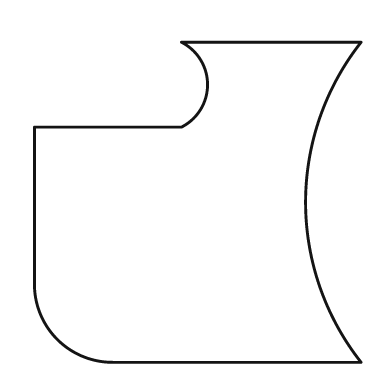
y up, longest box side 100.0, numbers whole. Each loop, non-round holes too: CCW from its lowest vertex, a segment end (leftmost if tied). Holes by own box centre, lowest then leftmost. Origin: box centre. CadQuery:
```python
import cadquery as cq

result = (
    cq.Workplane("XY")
    .moveTo(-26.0, -49.0)
    .lineTo(50.0, -49.0)
    .threePointArc((33.0, 0.0), (50.0, 49.0))
    .lineTo(-5.0, 49.0)
    .threePointArc((3.0, 36.0), (-5.0, 23.0))
    .lineTo(-50.0, 23.0)
    .lineTo(-50.0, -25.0)
    .threePointArc((-43.0, -42.0), (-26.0, -49.0))
    .close()
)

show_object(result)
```